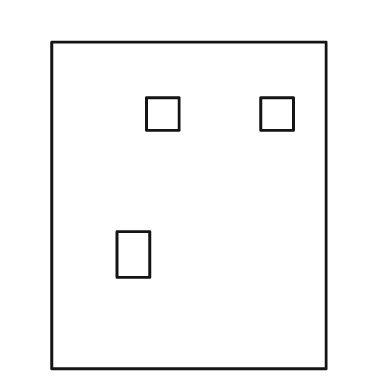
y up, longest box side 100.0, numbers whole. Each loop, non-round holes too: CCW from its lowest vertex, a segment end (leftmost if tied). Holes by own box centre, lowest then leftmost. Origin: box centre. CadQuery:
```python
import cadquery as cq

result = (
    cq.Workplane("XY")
    .moveTo(-42.0, -50.0)
    .lineTo(42.0, -50.0)
    .lineTo(42.0, 50.0)
    .lineTo(-42.0, 50.0)
    .close()
    .moveTo(-22.0, -22.0)
    .lineTo(-12.0, -22.0)
    .lineTo(-12.0, -8.0)
    .lineTo(-22.0, -8.0)
    .close()
    .moveTo(-13.0, 23.0)
    .lineTo(-3.0, 23.0)
    .lineTo(-3.0, 33.0)
    .lineTo(-13.0, 33.0)
    .close()
    .moveTo(22.0, 23.0)
    .lineTo(32.0, 23.0)
    .lineTo(32.0, 33.0)
    .lineTo(22.0, 33.0)
    .close()
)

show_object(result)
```